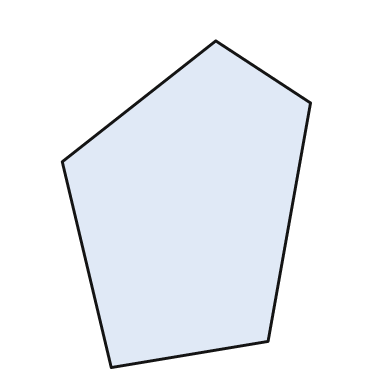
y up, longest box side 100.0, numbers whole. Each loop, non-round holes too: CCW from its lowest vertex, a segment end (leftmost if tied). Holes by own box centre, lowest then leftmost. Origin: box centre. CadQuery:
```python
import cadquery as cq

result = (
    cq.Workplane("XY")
    .moveTo(-23.0, -50.0)
    .lineTo(25.0, -42.0)
    .lineTo(38.0, 31.0)
    .lineTo(9.0, 50.0)
    .lineTo(-38.0, 13.0)
    .close()
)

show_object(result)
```